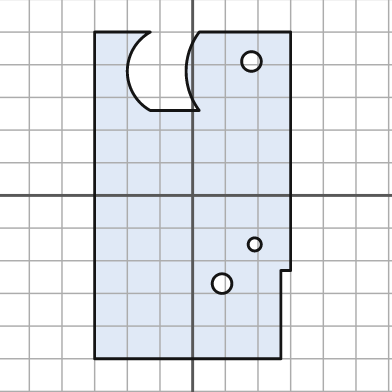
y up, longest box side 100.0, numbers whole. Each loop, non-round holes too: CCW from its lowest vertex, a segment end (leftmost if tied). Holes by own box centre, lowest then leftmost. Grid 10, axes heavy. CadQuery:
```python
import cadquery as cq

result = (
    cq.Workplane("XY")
    .moveTo(-30.0, -50.0)
    .lineTo(27.0, -50.0)
    .lineTo(27.0, -23.0)
    .lineTo(30.0, -23.0)
    .lineTo(30.0, 50.0)
    .lineTo(2.0, 50.0)
    .threePointArc((-2.0, 38.0), (2.0, 26.0))
    .lineTo(-13.0, 26.0)
    .threePointArc((-20.0, 38.0), (-13.0, 50.0))
    .lineTo(-30.0, 50.0)
    .close()
    .moveTo(9.0, -27.0)
    .circle(3.0)
    .moveTo(19.0, -15.0)
    .circle(2.0)
    .moveTo(18.0, 41.0)
    .circle(3.0)
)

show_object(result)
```